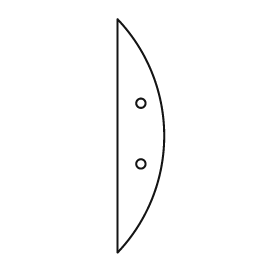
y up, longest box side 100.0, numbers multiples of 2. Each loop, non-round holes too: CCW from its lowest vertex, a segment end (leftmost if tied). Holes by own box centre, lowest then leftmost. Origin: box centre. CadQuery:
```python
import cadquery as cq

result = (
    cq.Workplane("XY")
    .moveTo(-10.0, -50.0)
    .threePointArc((10.0, 0.0), (-10.0, 50.0))
    .close()
    .moveTo(0.0, -12.0)
    .circle(2.0)
    .moveTo(0.0, 14.0)
    .circle(2.0)
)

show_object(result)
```